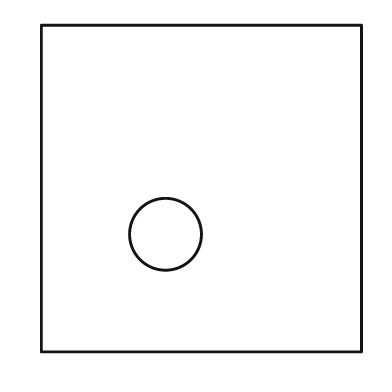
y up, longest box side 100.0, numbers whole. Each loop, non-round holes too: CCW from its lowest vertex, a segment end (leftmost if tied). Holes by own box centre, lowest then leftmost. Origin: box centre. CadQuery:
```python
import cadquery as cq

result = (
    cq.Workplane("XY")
    .moveTo(-49.0, -50.0)
    .lineTo(49.0, -50.0)
    .lineTo(49.0, 50.0)
    .lineTo(-49.0, 50.0)
    .close()
    .moveTo(-11.0, -14.0)
    .circle(11.0)
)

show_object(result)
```